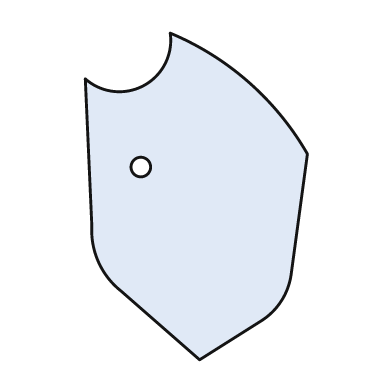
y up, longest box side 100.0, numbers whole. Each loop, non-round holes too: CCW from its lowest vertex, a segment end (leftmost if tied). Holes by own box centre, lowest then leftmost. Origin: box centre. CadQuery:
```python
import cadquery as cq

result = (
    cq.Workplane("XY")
    .moveTo(1.0, -50.0)
    .lineTo(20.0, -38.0)
    .threePointArc((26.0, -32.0), (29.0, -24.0))
    .lineTo(34.0, 13.0)
    .threePointArc((16.0, 35.0), (-8.0, 50.0))
    .threePointArc((-16.0, 34.0), (-34.0, 36.0))
    .lineTo(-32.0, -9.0)
    .threePointArc((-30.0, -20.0), (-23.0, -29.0))
    .close()
    .moveTo(-17.0, 9.0)
    .circle(3.0)
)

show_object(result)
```